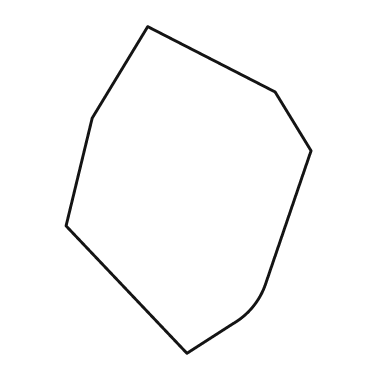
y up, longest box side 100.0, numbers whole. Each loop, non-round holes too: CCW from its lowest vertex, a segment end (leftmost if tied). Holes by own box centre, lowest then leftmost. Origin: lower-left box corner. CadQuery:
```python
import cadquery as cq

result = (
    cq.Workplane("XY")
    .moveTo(37.0, 0.0)
    .lineTo(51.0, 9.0)
    .threePointArc((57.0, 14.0), (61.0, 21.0))
    .lineTo(75.0, 62.0)
    .lineTo(64.0, 80.0)
    .lineTo(25.0, 100.0)
    .lineTo(8.0, 72.0)
    .lineTo(0.0, 39.0)
    .close()
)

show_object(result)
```